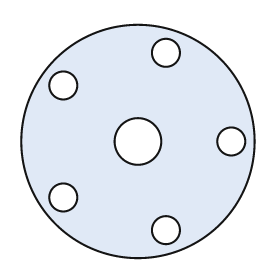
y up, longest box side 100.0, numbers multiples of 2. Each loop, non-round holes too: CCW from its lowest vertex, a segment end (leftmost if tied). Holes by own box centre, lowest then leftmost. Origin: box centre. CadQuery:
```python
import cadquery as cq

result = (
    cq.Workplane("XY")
    .moveTo(0.0, 0.0)
    .circle(50.0)
    .moveTo(12.0, -38.0)
    .circle(6.0)
    .moveTo(-32.0, -24.0)
    .circle(6.0)
    .moveTo(0.0, 0.0)
    .circle(10.0)
    .moveTo(40.0, 0.0)
    .circle(6.0)
    .moveTo(-32.0, 24.0)
    .circle(6.0)
    .moveTo(12.0, 38.0)
    .circle(6.0)
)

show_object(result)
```